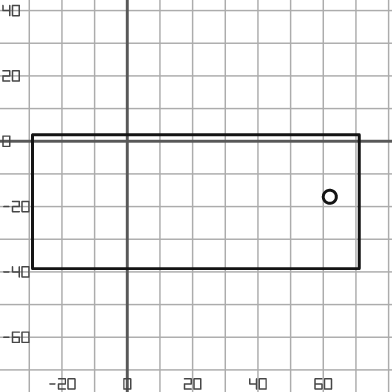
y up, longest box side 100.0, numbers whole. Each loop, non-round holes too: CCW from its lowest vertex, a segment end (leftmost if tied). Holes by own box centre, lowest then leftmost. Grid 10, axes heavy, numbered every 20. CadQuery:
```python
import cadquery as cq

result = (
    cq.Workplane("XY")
    .moveTo(-29.0, -39.0)
    .lineTo(71.0, -39.0)
    .lineTo(71.0, 2.0)
    .lineTo(-29.0, 2.0)
    .close()
    .moveTo(62.0, -17.0)
    .circle(2.0)
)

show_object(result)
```